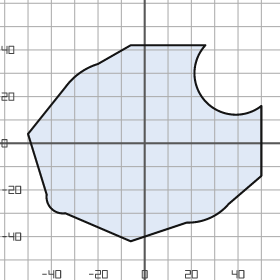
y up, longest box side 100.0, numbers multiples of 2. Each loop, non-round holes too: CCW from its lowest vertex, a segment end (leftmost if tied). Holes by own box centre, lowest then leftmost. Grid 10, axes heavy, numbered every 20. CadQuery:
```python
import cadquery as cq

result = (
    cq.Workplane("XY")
    .moveTo(-6.0, -42.0)
    .lineTo(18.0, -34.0)
    .threePointArc((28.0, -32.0), (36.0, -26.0))
    .lineTo(50.0, -14.0)
    .lineTo(50.0, 16.0)
    .threePointArc((26.0, 18.0), (26.0, 42.0))
    .lineTo(-6.0, 42.0)
    .lineTo(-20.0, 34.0)
    .threePointArc((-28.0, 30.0), (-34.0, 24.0))
    .lineTo(-50.0, 4.0)
    .lineTo(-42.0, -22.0)
    .threePointArc((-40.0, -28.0), (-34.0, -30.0))
    .close()
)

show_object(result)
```